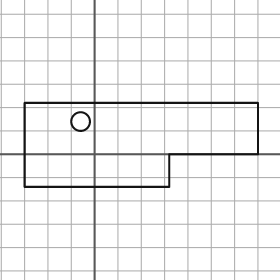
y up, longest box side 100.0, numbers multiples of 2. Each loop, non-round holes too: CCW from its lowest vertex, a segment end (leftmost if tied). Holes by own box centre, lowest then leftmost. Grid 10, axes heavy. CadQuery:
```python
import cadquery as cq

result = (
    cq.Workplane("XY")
    .moveTo(-30.0, -14.0)
    .lineTo(32.0, -14.0)
    .lineTo(32.0, 0.0)
    .lineTo(70.0, 0.0)
    .lineTo(70.0, 22.0)
    .lineTo(-30.0, 22.0)
    .close()
    .moveTo(-6.0, 14.0)
    .circle(4.0)
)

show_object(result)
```